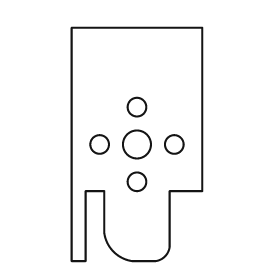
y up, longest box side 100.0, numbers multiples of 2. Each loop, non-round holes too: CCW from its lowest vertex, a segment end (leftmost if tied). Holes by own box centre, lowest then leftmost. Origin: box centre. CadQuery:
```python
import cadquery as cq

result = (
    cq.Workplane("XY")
    .moveTo(-28.0, -50.0)
    .lineTo(-22.0, -50.0)
    .lineTo(-22.0, -20.0)
    .lineTo(-14.0, -20.0)
    .lineTo(-14.0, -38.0)
    .threePointArc((-10.0, -46.0), (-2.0, -50.0))
    .lineTo(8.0, -50.0)
    .threePointArc((12.0, -48.0), (14.0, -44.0))
    .lineTo(14.0, -20.0)
    .lineTo(28.0, -20.0)
    .lineTo(28.0, 50.0)
    .lineTo(-28.0, 50.0)
    .close()
    .moveTo(0.0, -16.0)
    .circle(4.0)
    .moveTo(-16.0, 0.0)
    .circle(4.0)
    .moveTo(0.0, 0.0)
    .circle(6.0)
    .moveTo(16.0, 0.0)
    .circle(4.0)
    .moveTo(0.0, 16.0)
    .circle(4.0)
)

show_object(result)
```